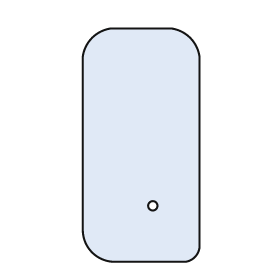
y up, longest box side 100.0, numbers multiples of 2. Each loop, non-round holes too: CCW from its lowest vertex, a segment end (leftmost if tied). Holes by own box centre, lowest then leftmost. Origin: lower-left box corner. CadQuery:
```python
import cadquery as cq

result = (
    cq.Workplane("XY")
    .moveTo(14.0, 0.0)
    .lineTo(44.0, 0.0)
    .threePointArc((48.0, 2.0), (50.0, 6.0))
    .lineTo(50.0, 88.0)
    .threePointArc((46.0, 96.0), (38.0, 100.0))
    .lineTo(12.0, 100.0)
    .threePointArc((4.0, 96.0), (0.0, 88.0))
    .lineTo(0.0, 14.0)
    .threePointArc((4.0, 4.0), (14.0, 0.0))
    .close()
    .moveTo(30.0, 24.0)
    .circle(2.0)
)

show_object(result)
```